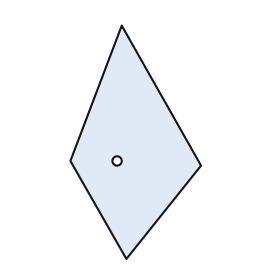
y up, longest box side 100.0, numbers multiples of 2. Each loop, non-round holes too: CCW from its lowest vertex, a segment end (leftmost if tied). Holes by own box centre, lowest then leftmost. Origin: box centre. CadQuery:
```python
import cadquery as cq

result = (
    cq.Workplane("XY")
    .moveTo(-4.0, -50.0)
    .lineTo(28.0, -10.0)
    .lineTo(-6.0, 50.0)
    .lineTo(-28.0, -8.0)
    .close()
    .moveTo(-8.0, -8.0)
    .circle(2.0)
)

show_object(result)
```